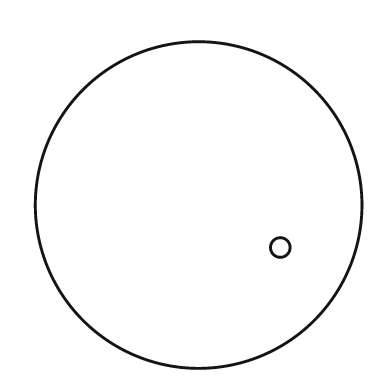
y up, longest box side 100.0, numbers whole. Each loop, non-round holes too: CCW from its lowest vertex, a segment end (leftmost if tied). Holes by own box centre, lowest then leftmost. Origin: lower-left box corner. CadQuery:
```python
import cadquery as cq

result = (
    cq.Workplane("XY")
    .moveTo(50.0, 50.0)
    .circle(50.0)
    .moveTo(75.0, 37.0)
    .circle(3.0)
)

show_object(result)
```